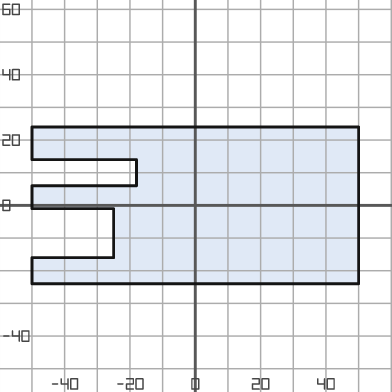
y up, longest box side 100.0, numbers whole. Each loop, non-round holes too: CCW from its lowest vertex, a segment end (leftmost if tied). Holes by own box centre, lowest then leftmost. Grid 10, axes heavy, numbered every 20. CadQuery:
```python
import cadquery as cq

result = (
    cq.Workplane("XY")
    .moveTo(-50.0, -24.0)
    .lineTo(50.0, -24.0)
    .lineTo(50.0, 24.0)
    .lineTo(-50.0, 24.0)
    .lineTo(-50.0, 14.0)
    .lineTo(-18.0, 14.0)
    .lineTo(-18.0, 6.0)
    .lineTo(-50.0, 6.0)
    .lineTo(-50.0, -1.0)
    .lineTo(-25.0, -1.0)
    .lineTo(-25.0, -16.0)
    .lineTo(-50.0, -16.0)
    .close()
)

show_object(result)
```